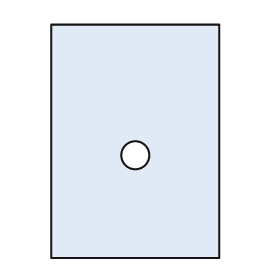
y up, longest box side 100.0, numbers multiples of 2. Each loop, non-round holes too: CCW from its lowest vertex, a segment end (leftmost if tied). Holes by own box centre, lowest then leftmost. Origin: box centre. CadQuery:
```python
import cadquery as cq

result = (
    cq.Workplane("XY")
    .moveTo(-36.0, -50.0)
    .lineTo(36.0, -50.0)
    .lineTo(36.0, 50.0)
    .lineTo(-36.0, 50.0)
    .close()
    .moveTo(0.0, -6.0)
    .circle(6.0)
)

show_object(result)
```